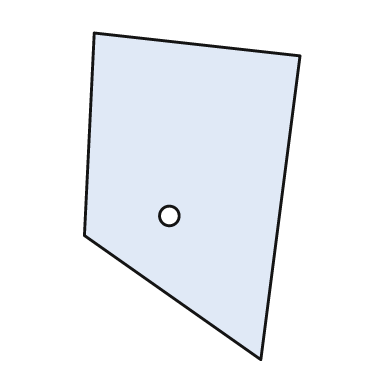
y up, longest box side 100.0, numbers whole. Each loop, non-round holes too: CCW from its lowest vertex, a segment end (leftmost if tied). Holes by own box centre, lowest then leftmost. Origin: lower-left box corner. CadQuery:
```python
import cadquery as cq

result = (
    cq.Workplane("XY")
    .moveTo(54.0, 0.0)
    .lineTo(66.0, 93.0)
    .lineTo(3.0, 100.0)
    .lineTo(0.0, 38.0)
    .close()
    .moveTo(26.0, 44.0)
    .circle(3.0)
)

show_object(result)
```